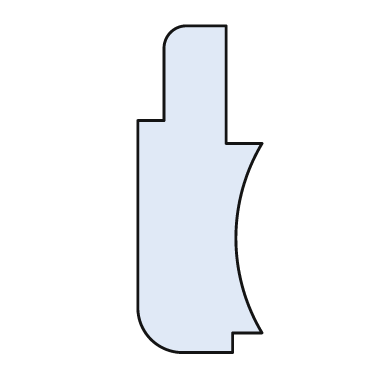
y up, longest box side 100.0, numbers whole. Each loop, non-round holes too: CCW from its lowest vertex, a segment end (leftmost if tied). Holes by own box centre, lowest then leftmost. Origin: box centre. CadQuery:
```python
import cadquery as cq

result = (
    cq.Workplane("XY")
    .moveTo(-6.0, -50.0)
    .lineTo(10.0, -50.0)
    .lineTo(10.0, -44.0)
    .lineTo(19.0, -44.0)
    .threePointArc((11.0, -15.0), (19.0, 14.0))
    .lineTo(8.0, 14.0)
    .lineTo(8.0, 50.0)
    .lineTo(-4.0, 50.0)
    .threePointArc((-9.0, 48.0), (-11.0, 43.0))
    .lineTo(-11.0, 21.0)
    .lineTo(-19.0, 21.0)
    .lineTo(-19.0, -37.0)
    .threePointArc((-15.0, -46.0), (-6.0, -50.0))
    .close()
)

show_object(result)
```